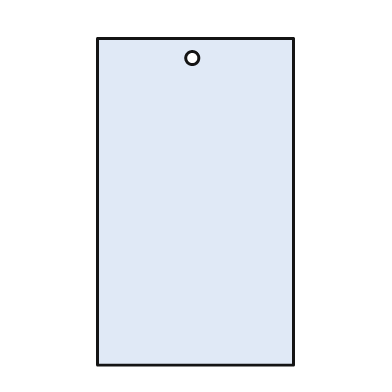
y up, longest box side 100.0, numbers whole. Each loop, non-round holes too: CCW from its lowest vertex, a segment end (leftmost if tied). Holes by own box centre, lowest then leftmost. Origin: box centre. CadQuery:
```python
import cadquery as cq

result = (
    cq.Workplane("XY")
    .moveTo(-30.0, -50.0)
    .lineTo(30.0, -50.0)
    .lineTo(30.0, 50.0)
    .lineTo(-30.0, 50.0)
    .close()
    .moveTo(-1.0, 44.0)
    .circle(2.0)
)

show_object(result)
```